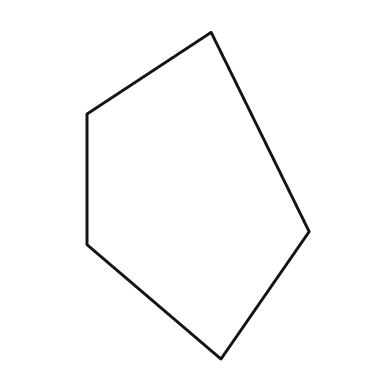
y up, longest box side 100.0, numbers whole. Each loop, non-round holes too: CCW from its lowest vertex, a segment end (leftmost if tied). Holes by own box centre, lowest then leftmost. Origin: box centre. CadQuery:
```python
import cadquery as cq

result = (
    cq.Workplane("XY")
    .moveTo(7.0, -50.0)
    .lineTo(34.0, -11.0)
    .lineTo(4.0, 50.0)
    .lineTo(-34.0, 25.0)
    .lineTo(-34.0, -15.0)
    .close()
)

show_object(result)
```